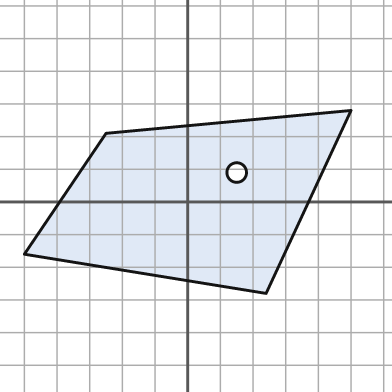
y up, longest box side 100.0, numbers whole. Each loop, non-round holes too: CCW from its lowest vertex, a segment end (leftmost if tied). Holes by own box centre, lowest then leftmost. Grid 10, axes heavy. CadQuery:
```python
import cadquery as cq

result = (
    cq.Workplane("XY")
    .moveTo(24.0, -28.0)
    .lineTo(50.0, 28.0)
    .lineTo(-25.0, 21.0)
    .lineTo(-50.0, -16.0)
    .close()
    .moveTo(15.0, 9.0)
    .circle(3.0)
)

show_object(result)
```